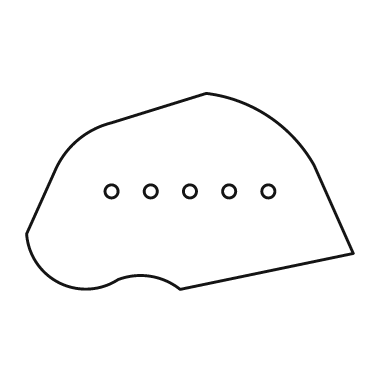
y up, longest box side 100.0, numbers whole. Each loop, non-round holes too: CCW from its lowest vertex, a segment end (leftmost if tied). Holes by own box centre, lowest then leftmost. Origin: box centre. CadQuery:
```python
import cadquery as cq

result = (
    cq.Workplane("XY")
    .moveTo(-3.0, -30.0)
    .lineTo(50.0, -19.0)
    .lineTo(38.0, 8.0)
    .threePointArc((24.0, 23.0), (5.0, 30.0))
    .lineTo(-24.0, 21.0)
    .threePointArc((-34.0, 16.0), (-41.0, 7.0))
    .lineTo(-50.0, -13.0)
    .threePointArc((-40.0, -28.0), (-22.0, -27.0))
    .threePointArc((-12.0, -26.0), (-3.0, -30.0))
    .close()
    .moveTo(-24.0, 0.0)
    .circle(2.0)
    .moveTo(-12.0, 0.0)
    .circle(2.0)
    .moveTo(0.0, 0.0)
    .circle(2.0)
    .moveTo(12.0, 0.0)
    .circle(2.0)
    .moveTo(24.0, 0.0)
    .circle(2.0)
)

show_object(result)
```